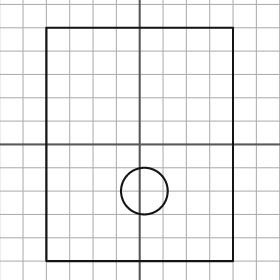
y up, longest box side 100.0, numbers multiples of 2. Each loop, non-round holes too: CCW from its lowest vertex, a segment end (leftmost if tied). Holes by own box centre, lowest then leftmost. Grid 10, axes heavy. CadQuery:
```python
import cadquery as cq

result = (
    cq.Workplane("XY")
    .moveTo(-40.0, -50.0)
    .lineTo(40.0, -50.0)
    .lineTo(40.0, 50.0)
    .lineTo(-40.0, 50.0)
    .close()
    .moveTo(2.0, -20.0)
    .circle(10.0)
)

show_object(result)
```